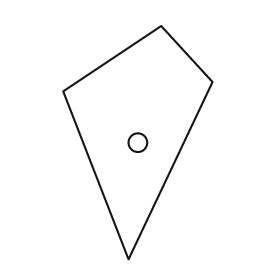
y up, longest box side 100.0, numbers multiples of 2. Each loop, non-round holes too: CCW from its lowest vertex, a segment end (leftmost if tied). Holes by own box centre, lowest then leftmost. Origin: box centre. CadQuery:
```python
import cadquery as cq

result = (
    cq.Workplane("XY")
    .moveTo(-4.0, -50.0)
    .lineTo(32.0, 26.0)
    .lineTo(10.0, 50.0)
    .lineTo(-32.0, 22.0)
    .close()
    .moveTo(0.0, 0.0)
    .circle(4.0)
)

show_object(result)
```